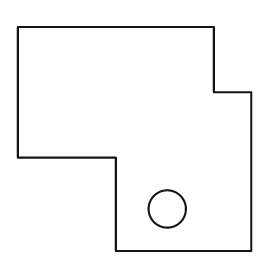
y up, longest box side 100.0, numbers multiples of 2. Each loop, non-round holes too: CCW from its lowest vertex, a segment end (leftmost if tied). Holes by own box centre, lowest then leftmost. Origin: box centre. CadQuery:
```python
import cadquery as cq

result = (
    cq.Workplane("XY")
    .moveTo(-8.0, -48.0)
    .lineTo(50.0, -48.0)
    .lineTo(50.0, 20.0)
    .lineTo(34.0, 20.0)
    .lineTo(34.0, 48.0)
    .lineTo(-50.0, 48.0)
    .lineTo(-50.0, -8.0)
    .lineTo(-8.0, -8.0)
    .close()
    .moveTo(14.0, -30.0)
    .circle(8.0)
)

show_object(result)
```